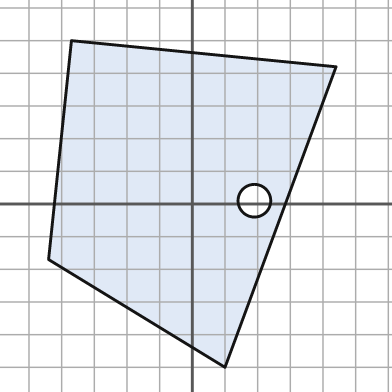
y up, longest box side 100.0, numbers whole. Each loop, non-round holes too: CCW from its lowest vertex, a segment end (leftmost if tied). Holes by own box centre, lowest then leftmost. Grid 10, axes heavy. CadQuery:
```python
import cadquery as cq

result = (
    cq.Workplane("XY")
    .moveTo(10.0, -50.0)
    .lineTo(44.0, 42.0)
    .lineTo(-37.0, 50.0)
    .lineTo(-44.0, -17.0)
    .close()
    .moveTo(19.0, 1.0)
    .circle(5.0)
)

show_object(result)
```